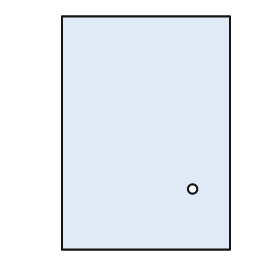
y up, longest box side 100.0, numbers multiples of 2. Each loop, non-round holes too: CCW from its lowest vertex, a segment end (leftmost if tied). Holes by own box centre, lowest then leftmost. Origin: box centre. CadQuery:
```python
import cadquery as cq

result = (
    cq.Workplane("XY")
    .moveTo(-36.0, -50.0)
    .lineTo(36.0, -50.0)
    .lineTo(36.0, 50.0)
    .lineTo(-36.0, 50.0)
    .close()
    .moveTo(20.0, -24.0)
    .circle(2.0)
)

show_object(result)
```